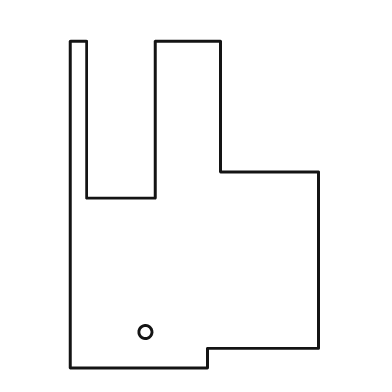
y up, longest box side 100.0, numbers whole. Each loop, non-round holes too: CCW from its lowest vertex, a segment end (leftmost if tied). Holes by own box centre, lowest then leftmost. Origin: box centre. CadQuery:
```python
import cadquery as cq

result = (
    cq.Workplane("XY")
    .moveTo(-38.0, -50.0)
    .lineTo(4.0, -50.0)
    .lineTo(4.0, -44.0)
    .lineTo(38.0, -44.0)
    .lineTo(38.0, 10.0)
    .lineTo(8.0, 10.0)
    .lineTo(8.0, 50.0)
    .lineTo(-12.0, 50.0)
    .lineTo(-12.0, 2.0)
    .lineTo(-33.0, 2.0)
    .lineTo(-33.0, 50.0)
    .lineTo(-38.0, 50.0)
    .close()
    .moveTo(-15.0, -39.0)
    .circle(2.0)
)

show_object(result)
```